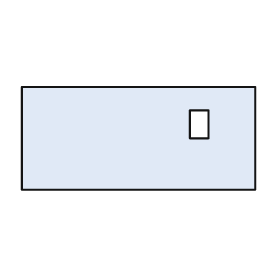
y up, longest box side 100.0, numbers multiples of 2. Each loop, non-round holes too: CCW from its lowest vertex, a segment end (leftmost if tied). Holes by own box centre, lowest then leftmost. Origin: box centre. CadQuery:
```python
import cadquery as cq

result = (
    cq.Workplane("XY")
    .moveTo(-50.0, -22.0)
    .lineTo(50.0, -22.0)
    .lineTo(50.0, 22.0)
    .lineTo(-50.0, 22.0)
    .close()
    .moveTo(22.0, 0.0)
    .lineTo(30.0, 0.0)
    .lineTo(30.0, 12.0)
    .lineTo(22.0, 12.0)
    .close()
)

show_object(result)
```